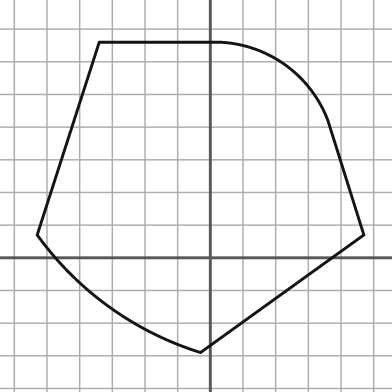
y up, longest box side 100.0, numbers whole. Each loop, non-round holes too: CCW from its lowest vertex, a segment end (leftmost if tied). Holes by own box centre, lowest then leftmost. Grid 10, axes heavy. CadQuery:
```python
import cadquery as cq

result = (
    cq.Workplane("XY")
    .moveTo(-3.0, -29.0)
    .lineTo(47.0, 7.0)
    .lineTo(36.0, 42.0)
    .threePointArc((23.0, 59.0), (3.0, 66.0))
    .lineTo(-34.0, 66.0)
    .lineTo(-53.0, 7.0)
    .threePointArc((-31.0, -15.0), (-3.0, -29.0))
    .close()
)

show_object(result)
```